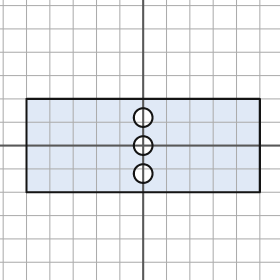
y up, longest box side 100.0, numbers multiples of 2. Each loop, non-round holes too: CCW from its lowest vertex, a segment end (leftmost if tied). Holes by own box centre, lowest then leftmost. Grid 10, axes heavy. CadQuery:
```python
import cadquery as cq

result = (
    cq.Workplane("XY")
    .moveTo(-50.0, -20.0)
    .lineTo(50.0, -20.0)
    .lineTo(50.0, 20.0)
    .lineTo(-50.0, 20.0)
    .close()
    .moveTo(0.0, -12.0)
    .circle(4.0)
    .moveTo(0.0, 0.0)
    .circle(4.0)
    .moveTo(0.0, 12.0)
    .circle(4.0)
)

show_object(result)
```